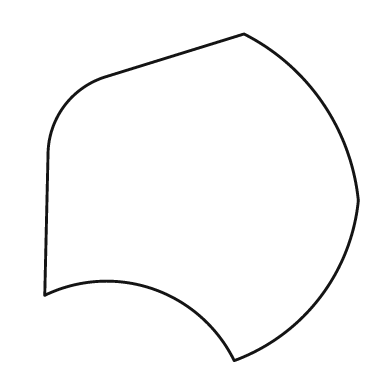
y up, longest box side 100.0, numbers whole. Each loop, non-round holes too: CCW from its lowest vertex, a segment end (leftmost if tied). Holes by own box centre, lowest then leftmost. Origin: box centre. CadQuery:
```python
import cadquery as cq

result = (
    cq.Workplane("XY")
    .moveTo(10.0, -50.0)
    .threePointArc((36.0, -31.0), (48.0, -1.0))
    .threePointArc((37.0, 29.0), (13.0, 50.0))
    .lineTo(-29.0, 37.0)
    .threePointArc((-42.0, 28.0), (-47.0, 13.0))
    .lineTo(-48.0, -30.0)
    .threePointArc((-15.0, -28.0), (10.0, -50.0))
    .close()
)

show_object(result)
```